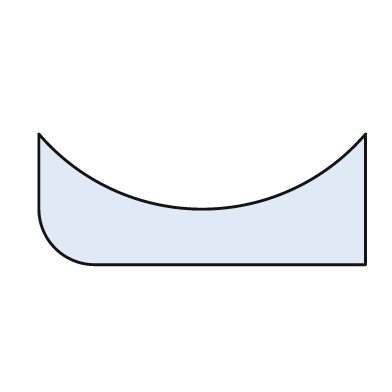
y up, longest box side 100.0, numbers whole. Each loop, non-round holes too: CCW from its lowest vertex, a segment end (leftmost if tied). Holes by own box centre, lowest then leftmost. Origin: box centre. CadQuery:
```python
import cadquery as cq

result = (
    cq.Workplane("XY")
    .moveTo(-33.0, -20.0)
    .lineTo(50.0, -20.0)
    .lineTo(50.0, 20.0)
    .threePointArc((0.0, -3.0), (-50.0, 20.0))
    .lineTo(-50.0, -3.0)
    .threePointArc((-45.0, -15.0), (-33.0, -20.0))
    .close()
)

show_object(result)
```